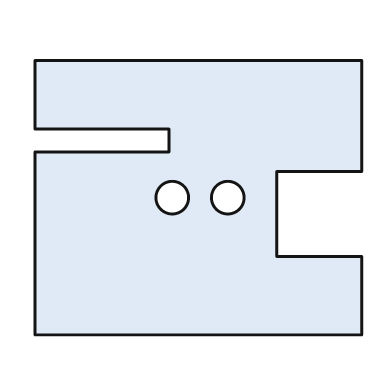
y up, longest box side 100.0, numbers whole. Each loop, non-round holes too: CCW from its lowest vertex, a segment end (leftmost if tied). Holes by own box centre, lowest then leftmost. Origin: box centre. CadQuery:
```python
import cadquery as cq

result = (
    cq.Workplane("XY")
    .moveTo(-50.0, -42.0)
    .lineTo(50.0, -42.0)
    .lineTo(50.0, -18.0)
    .lineTo(24.0, -18.0)
    .lineTo(24.0, 8.0)
    .lineTo(50.0, 8.0)
    .lineTo(50.0, 42.0)
    .lineTo(-50.0, 42.0)
    .lineTo(-50.0, 21.0)
    .lineTo(-9.0, 21.0)
    .lineTo(-9.0, 14.0)
    .lineTo(-50.0, 14.0)
    .close()
    .moveTo(-8.0, 0.0)
    .circle(5.0)
    .moveTo(9.0, 0.0)
    .circle(5.0)
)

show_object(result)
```